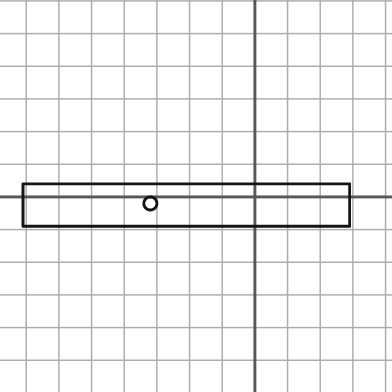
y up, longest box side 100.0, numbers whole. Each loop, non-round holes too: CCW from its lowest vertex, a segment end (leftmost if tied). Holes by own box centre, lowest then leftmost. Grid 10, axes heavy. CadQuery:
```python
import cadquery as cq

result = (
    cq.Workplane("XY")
    .moveTo(-71.0, -9.0)
    .lineTo(29.0, -9.0)
    .lineTo(29.0, 4.0)
    .lineTo(-71.0, 4.0)
    .close()
    .moveTo(-32.0, -2.0)
    .circle(2.0)
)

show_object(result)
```